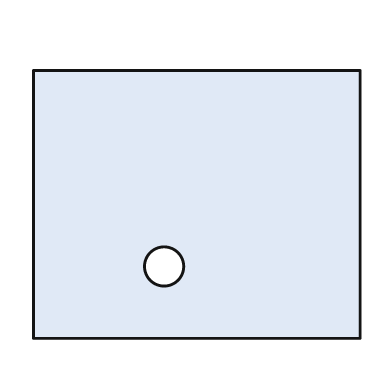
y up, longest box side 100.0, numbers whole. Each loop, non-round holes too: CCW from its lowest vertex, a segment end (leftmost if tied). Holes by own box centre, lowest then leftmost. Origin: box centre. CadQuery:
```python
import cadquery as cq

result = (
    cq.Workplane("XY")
    .moveTo(-50.0, -41.0)
    .lineTo(50.0, -41.0)
    .lineTo(50.0, 41.0)
    .lineTo(-50.0, 41.0)
    .close()
    .moveTo(-10.0, -19.0)
    .circle(6.0)
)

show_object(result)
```